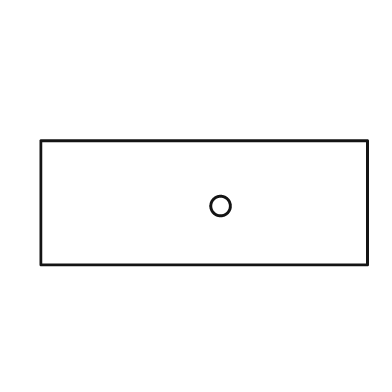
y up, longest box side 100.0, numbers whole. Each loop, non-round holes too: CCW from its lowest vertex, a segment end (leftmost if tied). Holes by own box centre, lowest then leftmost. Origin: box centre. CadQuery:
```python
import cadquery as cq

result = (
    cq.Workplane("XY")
    .moveTo(-50.0, -19.0)
    .lineTo(50.0, -19.0)
    .lineTo(50.0, 19.0)
    .lineTo(-50.0, 19.0)
    .close()
    .moveTo(5.0, -1.0)
    .circle(3.0)
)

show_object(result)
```